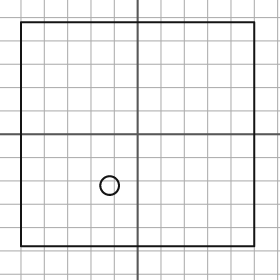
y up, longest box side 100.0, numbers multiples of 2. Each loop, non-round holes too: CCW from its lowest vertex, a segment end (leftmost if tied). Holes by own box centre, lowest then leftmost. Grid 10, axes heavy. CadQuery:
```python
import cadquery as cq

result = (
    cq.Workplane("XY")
    .moveTo(-50.0, -48.0)
    .lineTo(50.0, -48.0)
    .lineTo(50.0, 48.0)
    .lineTo(-50.0, 48.0)
    .close()
    .moveTo(-12.0, -22.0)
    .circle(4.0)
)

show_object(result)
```